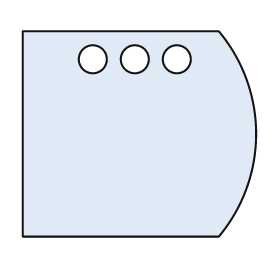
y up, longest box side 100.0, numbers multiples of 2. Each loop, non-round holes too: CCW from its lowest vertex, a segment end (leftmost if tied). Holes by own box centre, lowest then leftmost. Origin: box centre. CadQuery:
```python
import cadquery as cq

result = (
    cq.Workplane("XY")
    .moveTo(-50.0, -44.0)
    .lineTo(34.0, -44.0)
    .threePointArc((50.0, 0.0), (34.0, 44.0))
    .lineTo(-50.0, 44.0)
    .close()
    .moveTo(-20.0, 32.0)
    .circle(6.0)
    .moveTo(-2.0, 32.0)
    .circle(6.0)
    .moveTo(16.0, 32.0)
    .circle(6.0)
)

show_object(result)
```